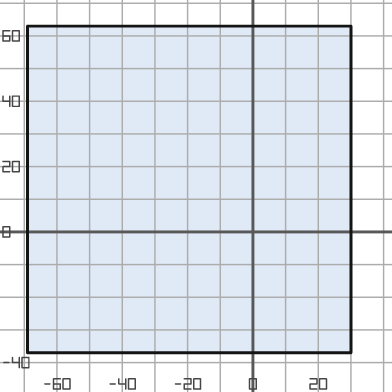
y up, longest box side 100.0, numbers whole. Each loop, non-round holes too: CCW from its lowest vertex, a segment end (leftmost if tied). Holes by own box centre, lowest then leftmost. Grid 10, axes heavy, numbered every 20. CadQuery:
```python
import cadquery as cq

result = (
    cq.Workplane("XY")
    .moveTo(-69.0, -37.0)
    .lineTo(30.0, -37.0)
    .lineTo(30.0, 63.0)
    .lineTo(-69.0, 63.0)
    .close()
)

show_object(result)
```